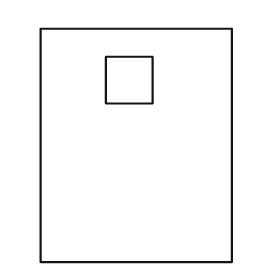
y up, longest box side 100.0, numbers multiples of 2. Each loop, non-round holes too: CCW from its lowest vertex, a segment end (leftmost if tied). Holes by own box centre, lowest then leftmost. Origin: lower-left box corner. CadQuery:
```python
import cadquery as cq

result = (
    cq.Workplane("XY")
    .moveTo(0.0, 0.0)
    .lineTo(82.0, 0.0)
    .lineTo(82.0, 100.0)
    .lineTo(0.0, 100.0)
    .close()
    .moveTo(28.0, 68.0)
    .lineTo(48.0, 68.0)
    .lineTo(48.0, 88.0)
    .lineTo(28.0, 88.0)
    .close()
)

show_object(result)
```